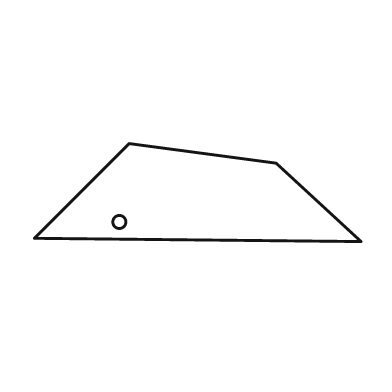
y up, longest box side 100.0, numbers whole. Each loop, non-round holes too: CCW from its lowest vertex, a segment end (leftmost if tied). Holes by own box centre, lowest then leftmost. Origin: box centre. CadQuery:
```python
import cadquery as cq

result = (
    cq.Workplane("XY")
    .moveTo(50.0, -15.0)
    .lineTo(24.0, 9.0)
    .lineTo(-21.0, 15.0)
    .lineTo(-50.0, -14.0)
    .close()
    .moveTo(-24.0, -9.0)
    .circle(2.0)
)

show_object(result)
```